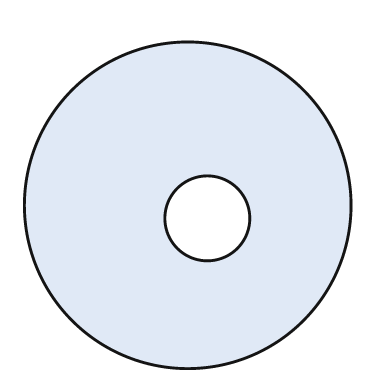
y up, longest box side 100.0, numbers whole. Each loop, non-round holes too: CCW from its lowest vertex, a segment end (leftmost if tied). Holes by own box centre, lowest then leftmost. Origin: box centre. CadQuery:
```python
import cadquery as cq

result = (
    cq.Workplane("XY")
    .moveTo(0.0, 0.0)
    .circle(50.0)
    .moveTo(6.0, -4.0)
    .circle(13.0)
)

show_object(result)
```